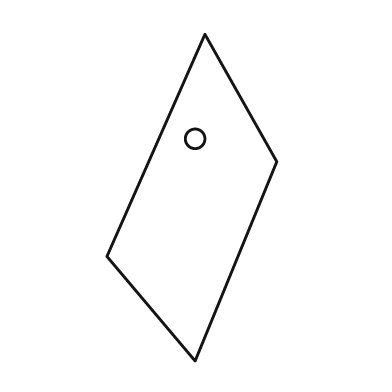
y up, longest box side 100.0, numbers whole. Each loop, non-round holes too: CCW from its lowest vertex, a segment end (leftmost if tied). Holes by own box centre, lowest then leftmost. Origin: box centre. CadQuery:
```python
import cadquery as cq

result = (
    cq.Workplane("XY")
    .moveTo(1.0, -50.0)
    .lineTo(26.0, 11.0)
    .lineTo(4.0, 50.0)
    .lineTo(-26.0, -18.0)
    .close()
    .moveTo(1.0, 18.0)
    .circle(3.0)
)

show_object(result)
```